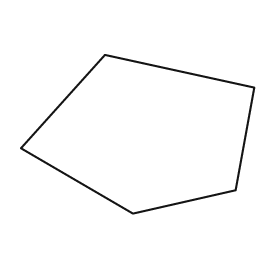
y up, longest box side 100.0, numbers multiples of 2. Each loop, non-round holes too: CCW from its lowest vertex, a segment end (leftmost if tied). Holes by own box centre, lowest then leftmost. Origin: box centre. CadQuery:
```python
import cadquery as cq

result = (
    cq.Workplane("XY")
    .moveTo(-2.0, -34.0)
    .lineTo(42.0, -24.0)
    .lineTo(50.0, 20.0)
    .lineTo(-14.0, 34.0)
    .lineTo(-50.0, -6.0)
    .close()
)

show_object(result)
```